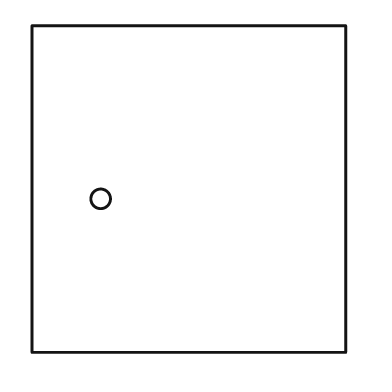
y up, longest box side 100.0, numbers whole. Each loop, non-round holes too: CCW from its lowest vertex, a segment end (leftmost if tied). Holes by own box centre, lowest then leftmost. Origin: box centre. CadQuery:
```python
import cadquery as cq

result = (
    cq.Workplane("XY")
    .moveTo(-48.0, -50.0)
    .lineTo(48.0, -50.0)
    .lineTo(48.0, 50.0)
    .lineTo(-48.0, 50.0)
    .close()
    .moveTo(-27.0, -3.0)
    .circle(3.0)
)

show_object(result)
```